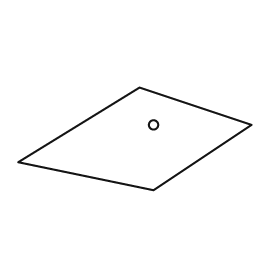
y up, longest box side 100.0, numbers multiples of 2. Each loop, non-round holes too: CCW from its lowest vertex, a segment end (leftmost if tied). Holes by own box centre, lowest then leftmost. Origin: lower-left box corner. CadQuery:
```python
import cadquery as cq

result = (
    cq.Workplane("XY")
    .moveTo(58.0, 0.0)
    .lineTo(100.0, 28.0)
    .lineTo(52.0, 44.0)
    .lineTo(0.0, 12.0)
    .close()
    .moveTo(58.0, 28.0)
    .circle(2.0)
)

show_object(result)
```